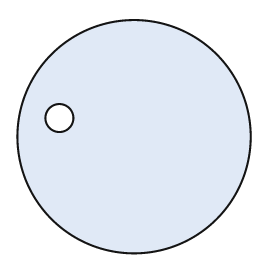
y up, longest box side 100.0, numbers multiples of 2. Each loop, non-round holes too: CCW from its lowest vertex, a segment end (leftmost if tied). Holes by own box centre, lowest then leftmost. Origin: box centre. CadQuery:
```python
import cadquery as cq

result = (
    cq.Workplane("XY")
    .moveTo(0.0, 0.0)
    .circle(50.0)
    .moveTo(-32.0, 8.0)
    .circle(6.0)
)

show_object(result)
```